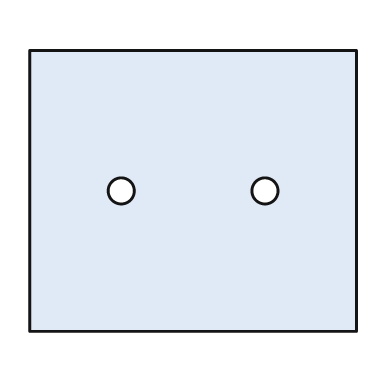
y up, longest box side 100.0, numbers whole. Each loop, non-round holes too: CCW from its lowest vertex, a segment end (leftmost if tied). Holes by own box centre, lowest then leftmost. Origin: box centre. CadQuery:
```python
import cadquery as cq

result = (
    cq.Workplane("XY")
    .moveTo(-50.0, -43.0)
    .lineTo(50.0, -43.0)
    .lineTo(50.0, 43.0)
    .lineTo(-50.0, 43.0)
    .close()
    .moveTo(-22.0, 0.0)
    .circle(4.0)
    .moveTo(22.0, 0.0)
    .circle(4.0)
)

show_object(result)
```